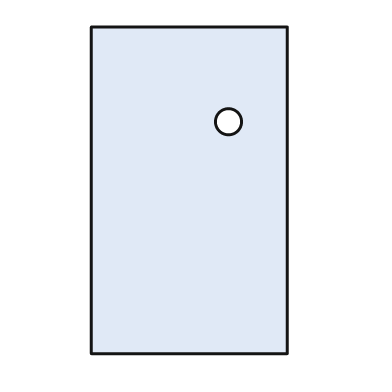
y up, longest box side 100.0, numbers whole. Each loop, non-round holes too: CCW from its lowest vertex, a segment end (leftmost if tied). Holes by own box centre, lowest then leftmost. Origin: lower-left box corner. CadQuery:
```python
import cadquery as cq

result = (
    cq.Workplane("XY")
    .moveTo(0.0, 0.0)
    .lineTo(60.0, 0.0)
    .lineTo(60.0, 100.0)
    .lineTo(0.0, 100.0)
    .close()
    .moveTo(42.0, 71.0)
    .circle(4.0)
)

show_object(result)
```